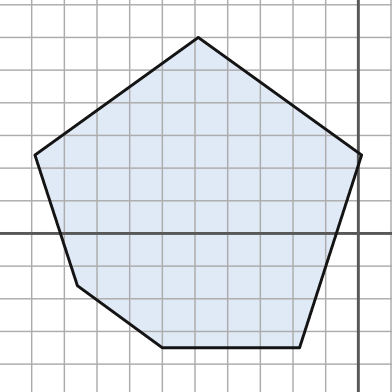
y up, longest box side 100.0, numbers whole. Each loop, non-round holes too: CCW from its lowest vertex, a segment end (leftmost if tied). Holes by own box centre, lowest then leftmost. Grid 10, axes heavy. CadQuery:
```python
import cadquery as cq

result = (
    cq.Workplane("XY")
    .moveTo(-60.0, -35.0)
    .lineTo(-18.0, -35.0)
    .lineTo(1.0, 24.0)
    .lineTo(-49.0, 60.0)
    .lineTo(-99.0, 24.0)
    .lineTo(-86.0, -16.0)
    .close()
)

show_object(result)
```